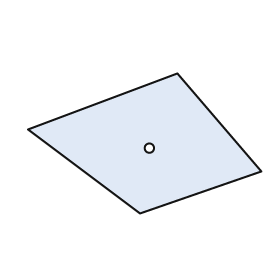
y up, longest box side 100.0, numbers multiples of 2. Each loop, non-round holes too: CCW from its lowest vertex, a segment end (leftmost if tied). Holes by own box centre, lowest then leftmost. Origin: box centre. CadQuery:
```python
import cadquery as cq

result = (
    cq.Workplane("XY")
    .moveTo(-2.0, -30.0)
    .lineTo(50.0, -12.0)
    .lineTo(14.0, 30.0)
    .lineTo(-50.0, 6.0)
    .close()
    .moveTo(2.0, -2.0)
    .circle(2.0)
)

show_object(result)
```